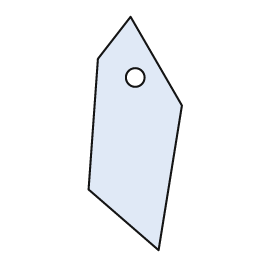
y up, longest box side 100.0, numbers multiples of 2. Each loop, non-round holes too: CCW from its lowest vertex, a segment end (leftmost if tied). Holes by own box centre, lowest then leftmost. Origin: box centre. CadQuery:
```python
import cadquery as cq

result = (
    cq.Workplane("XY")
    .moveTo(10.0, -50.0)
    .lineTo(20.0, 12.0)
    .lineTo(-2.0, 50.0)
    .lineTo(-16.0, 32.0)
    .lineTo(-20.0, -24.0)
    .close()
    .moveTo(0.0, 24.0)
    .circle(4.0)
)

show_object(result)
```